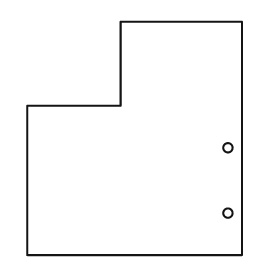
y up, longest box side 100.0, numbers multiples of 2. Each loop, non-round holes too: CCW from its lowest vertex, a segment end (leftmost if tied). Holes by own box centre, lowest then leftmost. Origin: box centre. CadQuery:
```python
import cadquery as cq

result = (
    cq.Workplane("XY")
    .moveTo(-46.0, -50.0)
    .lineTo(46.0, -50.0)
    .lineTo(46.0, 50.0)
    .lineTo(-6.0, 50.0)
    .lineTo(-6.0, 14.0)
    .lineTo(-46.0, 14.0)
    .close()
    .moveTo(40.0, -32.0)
    .circle(2.0)
    .moveTo(40.0, -4.0)
    .circle(2.0)
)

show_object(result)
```